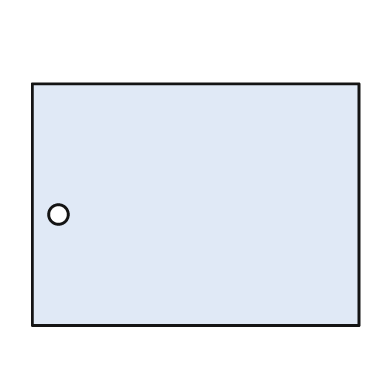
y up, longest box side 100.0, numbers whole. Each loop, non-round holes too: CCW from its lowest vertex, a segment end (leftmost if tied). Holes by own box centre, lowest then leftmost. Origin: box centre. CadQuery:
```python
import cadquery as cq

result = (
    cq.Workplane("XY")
    .moveTo(-50.0, -37.0)
    .lineTo(50.0, -37.0)
    .lineTo(50.0, 37.0)
    .lineTo(-50.0, 37.0)
    .close()
    .moveTo(-42.0, -3.0)
    .circle(3.0)
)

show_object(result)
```